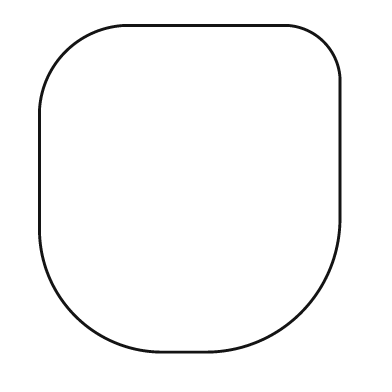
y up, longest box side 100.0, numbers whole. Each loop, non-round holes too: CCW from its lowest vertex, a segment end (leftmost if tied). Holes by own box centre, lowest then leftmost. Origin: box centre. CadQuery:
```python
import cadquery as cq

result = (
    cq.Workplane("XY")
    .moveTo(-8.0, -50.0)
    .lineTo(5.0, -50.0)
    .threePointArc((34.0, -38.0), (46.0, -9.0))
    .lineTo(46.0, 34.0)
    .threePointArc((41.0, 45.0), (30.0, 50.0))
    .lineTo(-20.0, 50.0)
    .threePointArc((-38.0, 42.0), (-46.0, 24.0))
    .lineTo(-46.0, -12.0)
    .threePointArc((-35.0, -39.0), (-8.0, -50.0))
    .close()
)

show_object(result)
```